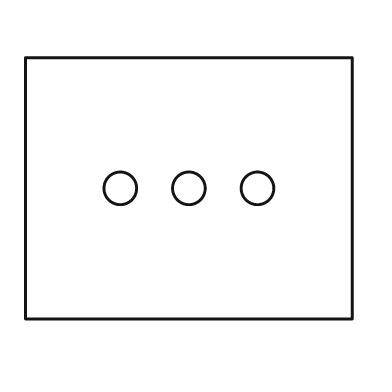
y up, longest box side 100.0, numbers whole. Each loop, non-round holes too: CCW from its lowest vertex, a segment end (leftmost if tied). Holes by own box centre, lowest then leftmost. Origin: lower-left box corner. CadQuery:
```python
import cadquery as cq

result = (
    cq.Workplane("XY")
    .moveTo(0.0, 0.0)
    .lineTo(100.0, 0.0)
    .lineTo(100.0, 80.0)
    .lineTo(0.0, 80.0)
    .close()
    .moveTo(29.0, 40.0)
    .circle(5.0)
    .moveTo(50.0, 40.0)
    .circle(5.0)
    .moveTo(71.0, 40.0)
    .circle(5.0)
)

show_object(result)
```